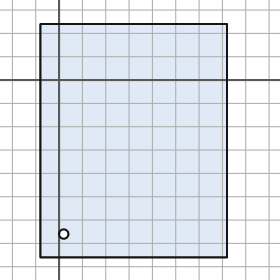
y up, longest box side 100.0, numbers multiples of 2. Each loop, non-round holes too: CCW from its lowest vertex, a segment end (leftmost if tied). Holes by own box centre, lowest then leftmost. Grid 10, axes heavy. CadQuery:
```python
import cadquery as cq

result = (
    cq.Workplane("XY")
    .moveTo(-8.0, -76.0)
    .lineTo(72.0, -76.0)
    .lineTo(72.0, 24.0)
    .lineTo(-8.0, 24.0)
    .close()
    .moveTo(2.0, -66.0)
    .circle(2.0)
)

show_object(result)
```